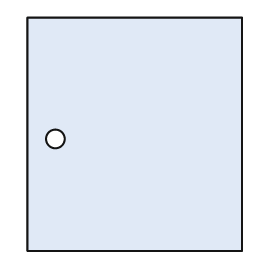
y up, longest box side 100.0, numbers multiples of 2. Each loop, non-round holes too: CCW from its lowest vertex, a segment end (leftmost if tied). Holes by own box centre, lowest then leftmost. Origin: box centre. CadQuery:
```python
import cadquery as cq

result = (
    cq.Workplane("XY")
    .moveTo(-46.0, -50.0)
    .lineTo(46.0, -50.0)
    .lineTo(46.0, 50.0)
    .lineTo(-46.0, 50.0)
    .close()
    .moveTo(-34.0, -2.0)
    .circle(4.0)
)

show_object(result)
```